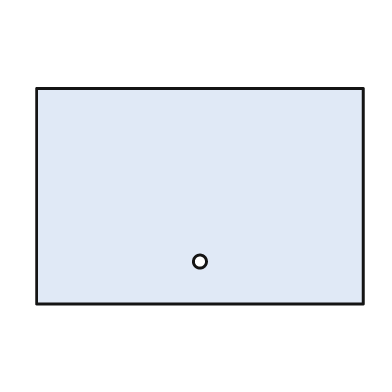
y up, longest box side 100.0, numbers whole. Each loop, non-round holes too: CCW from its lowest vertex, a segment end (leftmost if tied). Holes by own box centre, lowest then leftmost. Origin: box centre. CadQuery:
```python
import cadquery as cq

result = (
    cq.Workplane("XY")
    .moveTo(-50.0, -33.0)
    .lineTo(50.0, -33.0)
    .lineTo(50.0, 33.0)
    .lineTo(-50.0, 33.0)
    .close()
    .moveTo(0.0, -20.0)
    .circle(2.0)
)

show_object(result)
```